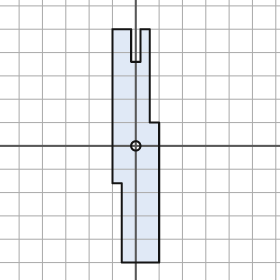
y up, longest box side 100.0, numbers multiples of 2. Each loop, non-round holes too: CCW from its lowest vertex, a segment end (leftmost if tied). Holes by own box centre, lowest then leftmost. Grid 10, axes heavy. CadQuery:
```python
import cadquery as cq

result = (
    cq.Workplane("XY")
    .moveTo(-6.0, -50.0)
    .lineTo(10.0, -50.0)
    .lineTo(10.0, 10.0)
    .lineTo(6.0, 10.0)
    .lineTo(6.0, 50.0)
    .lineTo(2.0, 50.0)
    .lineTo(2.0, 36.0)
    .lineTo(-2.0, 36.0)
    .lineTo(-2.0, 50.0)
    .lineTo(-10.0, 50.0)
    .lineTo(-10.0, -16.0)
    .lineTo(-6.0, -16.0)
    .close()
    .moveTo(0.0, 0.0)
    .circle(2.0)
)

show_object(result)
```